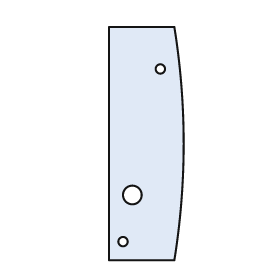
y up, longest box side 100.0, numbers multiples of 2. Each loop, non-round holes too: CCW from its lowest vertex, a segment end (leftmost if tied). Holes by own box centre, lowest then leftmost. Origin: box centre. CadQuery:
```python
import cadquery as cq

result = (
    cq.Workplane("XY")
    .moveTo(-16.0, -50.0)
    .lineTo(12.0, -50.0)
    .threePointArc((16.0, 0.0), (12.0, 50.0))
    .lineTo(-16.0, 50.0)
    .close()
    .moveTo(-10.0, -42.0)
    .circle(2.0)
    .moveTo(-6.0, -22.0)
    .circle(4.0)
    .moveTo(6.0, 32.0)
    .circle(2.0)
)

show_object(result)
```